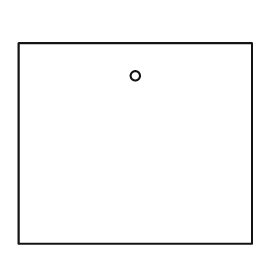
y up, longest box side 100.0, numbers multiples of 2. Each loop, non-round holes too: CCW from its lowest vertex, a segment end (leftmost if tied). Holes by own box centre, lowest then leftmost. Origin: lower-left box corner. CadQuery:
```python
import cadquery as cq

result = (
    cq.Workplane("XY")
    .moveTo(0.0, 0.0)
    .lineTo(100.0, 0.0)
    .lineTo(100.0, 86.0)
    .lineTo(0.0, 86.0)
    .close()
    .moveTo(50.0, 72.0)
    .circle(2.0)
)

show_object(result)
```